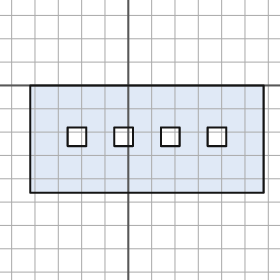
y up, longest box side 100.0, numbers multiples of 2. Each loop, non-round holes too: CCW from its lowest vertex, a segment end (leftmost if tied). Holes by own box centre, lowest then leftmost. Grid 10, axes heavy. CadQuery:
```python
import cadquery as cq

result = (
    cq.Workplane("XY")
    .moveTo(-42.0, -46.0)
    .lineTo(58.0, -46.0)
    .lineTo(58.0, 0.0)
    .lineTo(-42.0, 0.0)
    .close()
    .moveTo(-26.0, -26.0)
    .lineTo(-18.0, -26.0)
    .lineTo(-18.0, -18.0)
    .lineTo(-26.0, -18.0)
    .close()
    .moveTo(-6.0, -26.0)
    .lineTo(2.0, -26.0)
    .lineTo(2.0, -18.0)
    .lineTo(-6.0, -18.0)
    .close()
    .moveTo(14.0, -26.0)
    .lineTo(22.0, -26.0)
    .lineTo(22.0, -18.0)
    .lineTo(14.0, -18.0)
    .close()
    .moveTo(34.0, -26.0)
    .lineTo(42.0, -26.0)
    .lineTo(42.0, -18.0)
    .lineTo(34.0, -18.0)
    .close()
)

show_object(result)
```